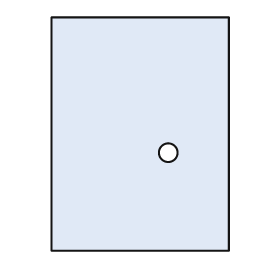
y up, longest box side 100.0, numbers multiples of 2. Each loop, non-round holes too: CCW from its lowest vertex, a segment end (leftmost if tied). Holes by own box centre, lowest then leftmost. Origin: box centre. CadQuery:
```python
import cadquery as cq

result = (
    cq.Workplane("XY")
    .moveTo(-38.0, -50.0)
    .lineTo(38.0, -50.0)
    .lineTo(38.0, 50.0)
    .lineTo(-38.0, 50.0)
    .close()
    .moveTo(12.0, -8.0)
    .circle(4.0)
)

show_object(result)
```